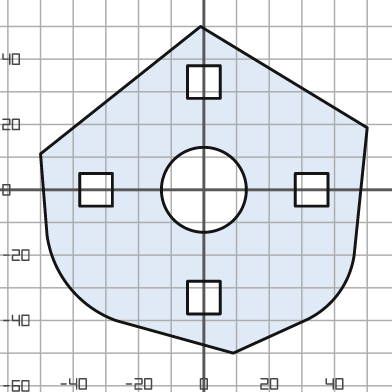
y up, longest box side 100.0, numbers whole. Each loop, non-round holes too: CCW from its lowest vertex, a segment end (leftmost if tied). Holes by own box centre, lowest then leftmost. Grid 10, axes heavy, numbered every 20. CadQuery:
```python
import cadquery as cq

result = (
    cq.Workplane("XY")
    .moveTo(9.0, -50.0)
    .lineTo(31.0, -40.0)
    .threePointArc((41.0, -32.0), (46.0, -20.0))
    .lineTo(50.0, 19.0)
    .lineTo(-1.0, 50.0)
    .lineTo(-50.0, 11.0)
    .lineTo(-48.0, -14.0)
    .threePointArc((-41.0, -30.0), (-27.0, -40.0))
    .close()
    .moveTo(-5.0, -38.0)
    .lineTo(5.0, -38.0)
    .lineTo(5.0, -28.0)
    .lineTo(-5.0, -28.0)
    .close()
    .moveTo(-38.0, -5.0)
    .lineTo(-28.0, -5.0)
    .lineTo(-28.0, 5.0)
    .lineTo(-38.0, 5.0)
    .close()
    .moveTo(0.0, 0.0)
    .circle(13.0)
    .moveTo(28.0, -5.0)
    .lineTo(38.0, -5.0)
    .lineTo(38.0, 5.0)
    .lineTo(28.0, 5.0)
    .close()
    .moveTo(-5.0, 28.0)
    .lineTo(5.0, 28.0)
    .lineTo(5.0, 38.0)
    .lineTo(-5.0, 38.0)
    .close()
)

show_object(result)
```